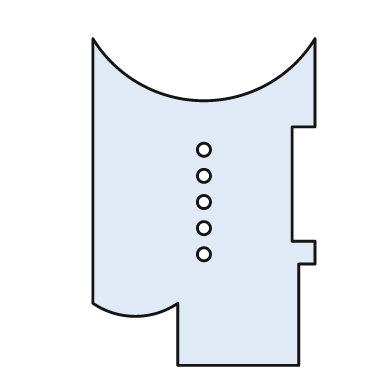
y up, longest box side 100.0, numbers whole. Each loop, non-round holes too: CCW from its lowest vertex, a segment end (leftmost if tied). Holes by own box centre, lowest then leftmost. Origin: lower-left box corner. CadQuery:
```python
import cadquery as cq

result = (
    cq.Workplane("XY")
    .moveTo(26.0, 0.0)
    .lineTo(63.0, 0.0)
    .lineTo(63.0, 31.0)
    .lineTo(68.0, 31.0)
    .lineTo(68.0, 38.0)
    .lineTo(61.0, 38.0)
    .lineTo(61.0, 73.0)
    .lineTo(68.0, 73.0)
    .lineTo(68.0, 100.0)
    .threePointArc((34.0, 81.0), (0.0, 100.0))
    .lineTo(0.0, 19.0)
    .threePointArc((13.0, 15.0), (26.0, 19.0))
    .close()
    .moveTo(34.0, 34.0)
    .circle(2.0)
    .moveTo(34.0, 42.0)
    .circle(2.0)
    .moveTo(34.0, 50.0)
    .circle(2.0)
    .moveTo(34.0, 58.0)
    .circle(2.0)
    .moveTo(34.0, 66.0)
    .circle(2.0)
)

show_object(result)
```